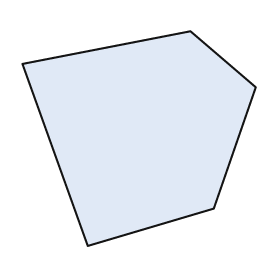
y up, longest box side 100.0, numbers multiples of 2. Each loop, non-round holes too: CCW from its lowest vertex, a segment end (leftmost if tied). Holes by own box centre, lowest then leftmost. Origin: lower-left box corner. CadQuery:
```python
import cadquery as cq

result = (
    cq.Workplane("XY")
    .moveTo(28.0, 0.0)
    .lineTo(82.0, 16.0)
    .lineTo(100.0, 68.0)
    .lineTo(72.0, 92.0)
    .lineTo(0.0, 78.0)
    .close()
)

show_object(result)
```